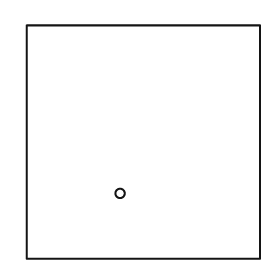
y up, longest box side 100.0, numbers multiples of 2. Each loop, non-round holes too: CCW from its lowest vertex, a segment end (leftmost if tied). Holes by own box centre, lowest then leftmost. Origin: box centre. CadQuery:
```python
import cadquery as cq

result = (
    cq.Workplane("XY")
    .moveTo(-50.0, -50.0)
    .lineTo(50.0, -50.0)
    .lineTo(50.0, 50.0)
    .lineTo(-50.0, 50.0)
    .close()
    .moveTo(-10.0, -22.0)
    .circle(2.0)
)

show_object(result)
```